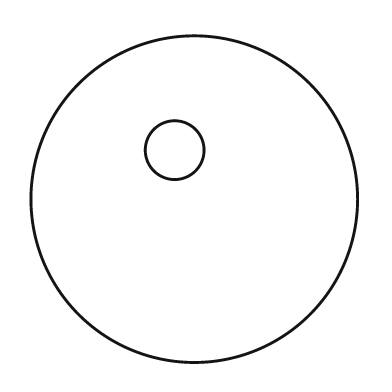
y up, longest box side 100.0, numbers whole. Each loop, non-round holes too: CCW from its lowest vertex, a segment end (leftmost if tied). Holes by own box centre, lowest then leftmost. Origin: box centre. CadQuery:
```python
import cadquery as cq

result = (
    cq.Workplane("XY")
    .moveTo(0.0, 0.0)
    .circle(50.0)
    .moveTo(-6.0, 15.0)
    .circle(9.0)
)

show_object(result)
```